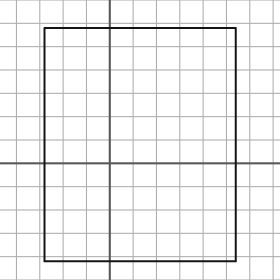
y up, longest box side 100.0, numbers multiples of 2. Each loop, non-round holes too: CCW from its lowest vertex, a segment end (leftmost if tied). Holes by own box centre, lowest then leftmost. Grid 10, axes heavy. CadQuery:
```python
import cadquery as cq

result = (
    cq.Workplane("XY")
    .moveTo(-28.0, -42.0)
    .lineTo(54.0, -42.0)
    .lineTo(54.0, 58.0)
    .lineTo(-28.0, 58.0)
    .close()
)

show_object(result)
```